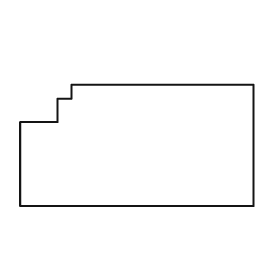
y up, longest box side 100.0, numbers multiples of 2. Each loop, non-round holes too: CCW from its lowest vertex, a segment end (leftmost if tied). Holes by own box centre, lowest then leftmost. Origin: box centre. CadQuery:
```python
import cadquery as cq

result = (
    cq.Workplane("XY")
    .moveTo(-50.0, -26.0)
    .lineTo(50.0, -26.0)
    .lineTo(50.0, 26.0)
    .lineTo(-28.0, 26.0)
    .lineTo(-28.0, 20.0)
    .lineTo(-34.0, 20.0)
    .lineTo(-34.0, 10.0)
    .lineTo(-50.0, 10.0)
    .close()
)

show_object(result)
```